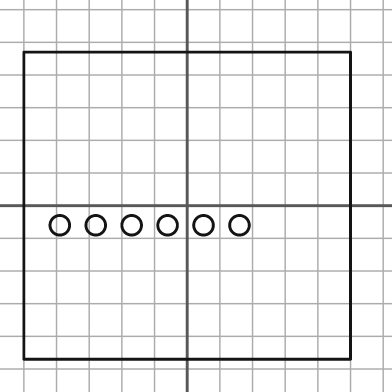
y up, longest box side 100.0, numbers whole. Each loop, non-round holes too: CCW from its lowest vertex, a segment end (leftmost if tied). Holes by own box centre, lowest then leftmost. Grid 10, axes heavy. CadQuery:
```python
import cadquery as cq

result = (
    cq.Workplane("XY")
    .moveTo(-50.0, -47.0)
    .lineTo(50.0, -47.0)
    .lineTo(50.0, 47.0)
    .lineTo(-50.0, 47.0)
    .close()
    .moveTo(-39.0, -6.0)
    .circle(3.0)
    .moveTo(-28.0, -6.0)
    .circle(3.0)
    .moveTo(-17.0, -6.0)
    .circle(3.0)
    .moveTo(-6.0, -6.0)
    .circle(3.0)
    .moveTo(5.0, -6.0)
    .circle(3.0)
    .moveTo(16.0, -6.0)
    .circle(3.0)
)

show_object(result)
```